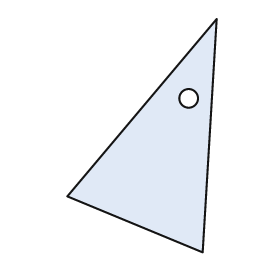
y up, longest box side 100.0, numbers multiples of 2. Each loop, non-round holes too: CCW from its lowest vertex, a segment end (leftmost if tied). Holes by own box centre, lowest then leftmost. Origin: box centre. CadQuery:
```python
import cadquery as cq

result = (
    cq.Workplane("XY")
    .moveTo(26.0, -50.0)
    .lineTo(32.0, 50.0)
    .lineTo(-32.0, -26.0)
    .close()
    .moveTo(20.0, 16.0)
    .circle(4.0)
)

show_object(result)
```